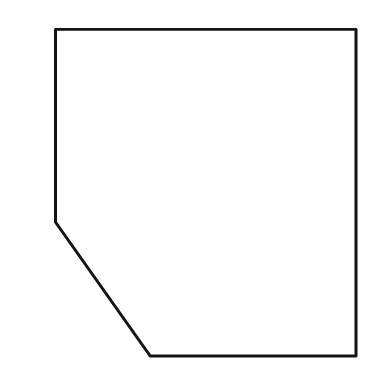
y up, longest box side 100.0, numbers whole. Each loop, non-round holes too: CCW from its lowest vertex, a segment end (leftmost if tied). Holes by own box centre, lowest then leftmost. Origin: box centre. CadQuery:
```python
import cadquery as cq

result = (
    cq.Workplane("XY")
    .moveTo(-17.0, -50.0)
    .lineTo(46.0, -50.0)
    .lineTo(46.0, 50.0)
    .lineTo(-46.0, 50.0)
    .lineTo(-46.0, -9.0)
    .close()
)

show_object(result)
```